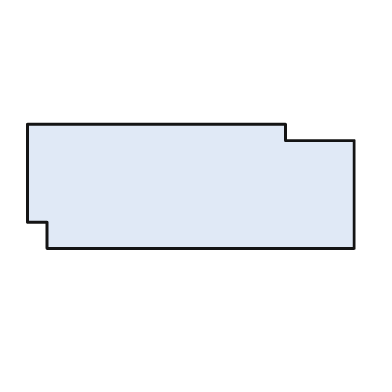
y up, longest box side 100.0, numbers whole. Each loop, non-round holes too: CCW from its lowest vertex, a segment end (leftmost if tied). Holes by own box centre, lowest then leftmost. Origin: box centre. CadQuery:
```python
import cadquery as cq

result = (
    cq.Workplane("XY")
    .moveTo(-44.0, -19.0)
    .lineTo(50.0, -19.0)
    .lineTo(50.0, 14.0)
    .lineTo(29.0, 14.0)
    .lineTo(29.0, 19.0)
    .lineTo(-50.0, 19.0)
    .lineTo(-50.0, -11.0)
    .lineTo(-44.0, -11.0)
    .close()
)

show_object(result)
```